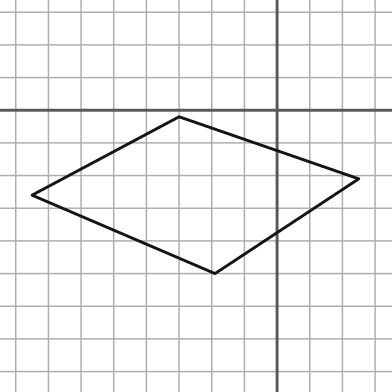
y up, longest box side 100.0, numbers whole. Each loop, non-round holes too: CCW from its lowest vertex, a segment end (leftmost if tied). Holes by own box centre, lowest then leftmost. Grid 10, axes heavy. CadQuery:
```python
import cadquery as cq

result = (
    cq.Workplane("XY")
    .moveTo(-19.0, -50.0)
    .lineTo(25.0, -21.0)
    .lineTo(-30.0, -2.0)
    .lineTo(-75.0, -26.0)
    .close()
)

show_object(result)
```